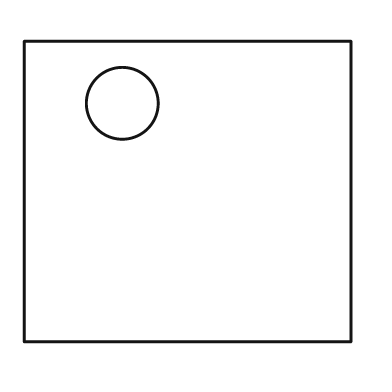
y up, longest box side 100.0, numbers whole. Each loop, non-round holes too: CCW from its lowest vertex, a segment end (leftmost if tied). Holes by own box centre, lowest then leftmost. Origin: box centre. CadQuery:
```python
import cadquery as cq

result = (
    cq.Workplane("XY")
    .moveTo(-50.0, -46.0)
    .lineTo(50.0, -46.0)
    .lineTo(50.0, 46.0)
    .lineTo(-50.0, 46.0)
    .close()
    .moveTo(-20.0, 27.0)
    .circle(11.0)
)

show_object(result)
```